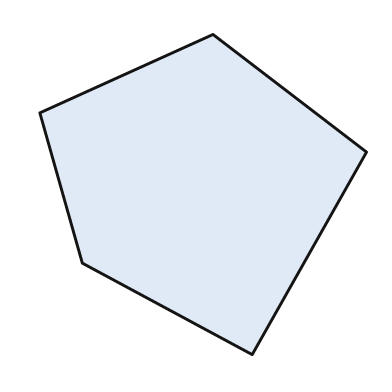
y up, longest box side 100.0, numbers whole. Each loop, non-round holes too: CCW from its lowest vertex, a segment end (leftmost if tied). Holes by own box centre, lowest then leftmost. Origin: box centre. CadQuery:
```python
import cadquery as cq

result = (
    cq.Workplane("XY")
    .moveTo(15.0, -49.0)
    .lineTo(50.0, 13.0)
    .lineTo(3.0, 49.0)
    .lineTo(-50.0, 25.0)
    .lineTo(-37.0, -21.0)
    .close()
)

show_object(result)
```